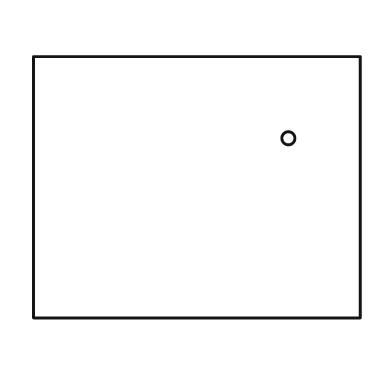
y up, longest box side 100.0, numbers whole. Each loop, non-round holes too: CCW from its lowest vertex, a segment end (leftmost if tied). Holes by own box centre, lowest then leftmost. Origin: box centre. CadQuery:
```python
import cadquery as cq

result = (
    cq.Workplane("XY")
    .moveTo(-50.0, -40.0)
    .lineTo(50.0, -40.0)
    .lineTo(50.0, 40.0)
    .lineTo(-50.0, 40.0)
    .close()
    .moveTo(28.0, 15.0)
    .circle(2.0)
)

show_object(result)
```